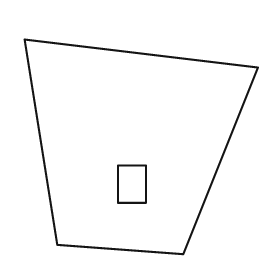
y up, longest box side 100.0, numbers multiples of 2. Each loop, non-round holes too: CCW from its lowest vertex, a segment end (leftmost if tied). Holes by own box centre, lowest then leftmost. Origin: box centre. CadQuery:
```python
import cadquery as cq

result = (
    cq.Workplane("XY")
    .moveTo(18.0, -46.0)
    .lineTo(50.0, 34.0)
    .lineTo(-50.0, 46.0)
    .lineTo(-36.0, -42.0)
    .close()
    .moveTo(-10.0, -24.0)
    .lineTo(2.0, -24.0)
    .lineTo(2.0, -8.0)
    .lineTo(-10.0, -8.0)
    .close()
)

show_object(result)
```